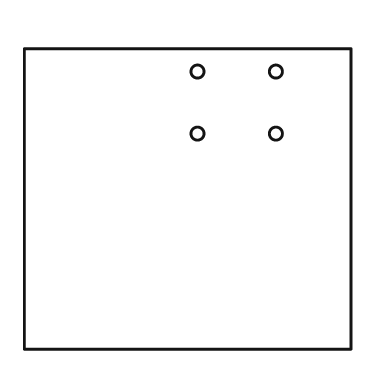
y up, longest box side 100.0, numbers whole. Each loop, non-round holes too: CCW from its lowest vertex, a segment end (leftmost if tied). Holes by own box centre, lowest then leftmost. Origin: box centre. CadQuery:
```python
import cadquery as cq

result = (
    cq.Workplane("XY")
    .moveTo(-50.0, -46.0)
    .lineTo(50.0, -46.0)
    .lineTo(50.0, 46.0)
    .lineTo(-50.0, 46.0)
    .close()
    .moveTo(3.0, 20.0)
    .circle(2.0)
    .moveTo(27.0, 20.0)
    .circle(2.0)
    .moveTo(3.0, 39.0)
    .circle(2.0)
    .moveTo(27.0, 39.0)
    .circle(2.0)
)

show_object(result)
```